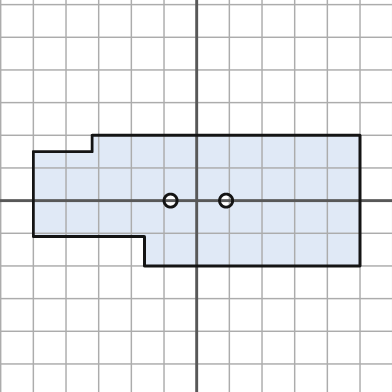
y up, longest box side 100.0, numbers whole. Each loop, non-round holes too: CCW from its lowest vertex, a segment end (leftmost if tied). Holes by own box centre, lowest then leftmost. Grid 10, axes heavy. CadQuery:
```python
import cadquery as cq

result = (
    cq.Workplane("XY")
    .moveTo(-16.0, -20.0)
    .lineTo(50.0, -20.0)
    .lineTo(50.0, 20.0)
    .lineTo(-32.0, 20.0)
    .lineTo(-32.0, 15.0)
    .lineTo(-50.0, 15.0)
    .lineTo(-50.0, -11.0)
    .lineTo(-16.0, -11.0)
    .close()
    .moveTo(-8.0, 0.0)
    .circle(2.0)
    .moveTo(9.0, 0.0)
    .circle(2.0)
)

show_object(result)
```